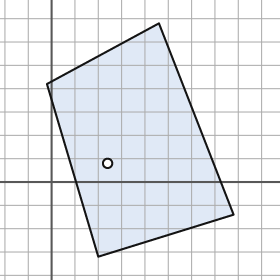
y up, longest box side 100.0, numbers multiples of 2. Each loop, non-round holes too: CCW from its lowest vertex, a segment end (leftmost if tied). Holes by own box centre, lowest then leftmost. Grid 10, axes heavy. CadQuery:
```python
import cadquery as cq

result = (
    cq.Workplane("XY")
    .moveTo(20.0, -32.0)
    .lineTo(78.0, -14.0)
    .lineTo(46.0, 68.0)
    .lineTo(-2.0, 42.0)
    .close()
    .moveTo(24.0, 8.0)
    .circle(2.0)
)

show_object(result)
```